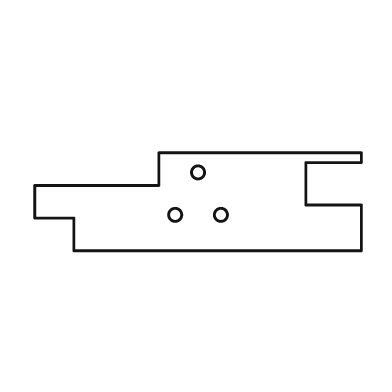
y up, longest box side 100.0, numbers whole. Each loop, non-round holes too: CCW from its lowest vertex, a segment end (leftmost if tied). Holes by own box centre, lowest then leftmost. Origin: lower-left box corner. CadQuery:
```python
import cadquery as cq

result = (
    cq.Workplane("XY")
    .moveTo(12.0, 0.0)
    .lineTo(100.0, 0.0)
    .lineTo(100.0, 14.0)
    .lineTo(83.0, 14.0)
    .lineTo(83.0, 27.0)
    .lineTo(100.0, 27.0)
    .lineTo(100.0, 30.0)
    .lineTo(38.0, 30.0)
    .lineTo(38.0, 20.0)
    .lineTo(0.0, 20.0)
    .lineTo(0.0, 10.0)
    .lineTo(12.0, 10.0)
    .close()
    .moveTo(43.0, 11.0)
    .circle(2.0)
    .moveTo(57.0, 11.0)
    .circle(2.0)
    .moveTo(50.0, 24.0)
    .circle(2.0)
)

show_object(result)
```